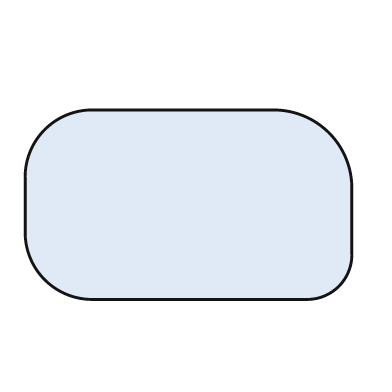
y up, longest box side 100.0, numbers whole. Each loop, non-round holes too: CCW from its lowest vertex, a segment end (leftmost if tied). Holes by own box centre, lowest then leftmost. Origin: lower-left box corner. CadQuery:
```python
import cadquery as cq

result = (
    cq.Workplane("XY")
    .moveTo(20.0, 0.0)
    .lineTo(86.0, 0.0)
    .threePointArc((96.0, 4.0), (100.0, 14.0))
    .lineTo(100.0, 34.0)
    .threePointArc((93.0, 51.0), (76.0, 58.0))
    .lineTo(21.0, 58.0)
    .threePointArc((6.0, 52.0), (0.0, 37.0))
    .lineTo(0.0, 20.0)
    .threePointArc((6.0, 6.0), (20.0, 0.0))
    .close()
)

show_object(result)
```